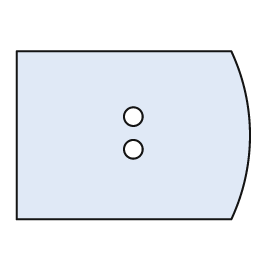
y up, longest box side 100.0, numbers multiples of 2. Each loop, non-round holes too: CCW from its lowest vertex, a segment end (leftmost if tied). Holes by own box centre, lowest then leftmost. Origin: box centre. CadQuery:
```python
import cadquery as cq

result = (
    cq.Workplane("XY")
    .moveTo(-50.0, -36.0)
    .lineTo(42.0, -36.0)
    .threePointArc((50.0, 0.0), (42.0, 36.0))
    .lineTo(-50.0, 36.0)
    .close()
    .moveTo(0.0, -6.0)
    .circle(4.0)
    .moveTo(0.0, 8.0)
    .circle(4.0)
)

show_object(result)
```